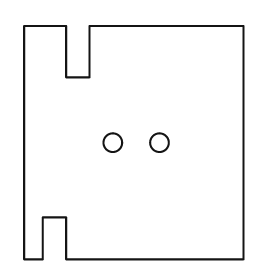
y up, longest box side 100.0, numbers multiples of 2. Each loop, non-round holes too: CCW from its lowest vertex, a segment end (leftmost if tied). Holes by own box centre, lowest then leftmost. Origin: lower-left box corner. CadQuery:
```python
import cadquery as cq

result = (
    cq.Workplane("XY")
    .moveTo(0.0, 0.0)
    .lineTo(8.0, 0.0)
    .lineTo(8.0, 18.0)
    .lineTo(18.0, 18.0)
    .lineTo(18.0, 0.0)
    .lineTo(94.0, 0.0)
    .lineTo(94.0, 100.0)
    .lineTo(28.0, 100.0)
    .lineTo(28.0, 78.0)
    .lineTo(18.0, 78.0)
    .lineTo(18.0, 100.0)
    .lineTo(0.0, 100.0)
    .close()
    .moveTo(38.0, 50.0)
    .circle(4.0)
    .moveTo(58.0, 50.0)
    .circle(4.0)
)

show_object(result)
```